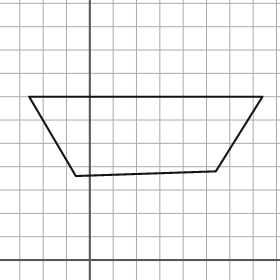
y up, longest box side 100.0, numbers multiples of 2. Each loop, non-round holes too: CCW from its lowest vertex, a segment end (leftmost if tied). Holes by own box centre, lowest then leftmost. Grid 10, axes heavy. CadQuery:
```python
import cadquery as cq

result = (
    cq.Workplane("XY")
    .moveTo(-6.0, 36.0)
    .lineTo(54.0, 38.0)
    .lineTo(74.0, 70.0)
    .lineTo(-26.0, 70.0)
    .close()
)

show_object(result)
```